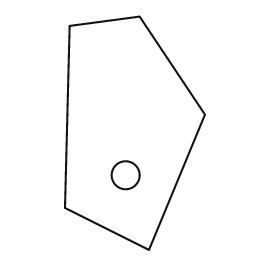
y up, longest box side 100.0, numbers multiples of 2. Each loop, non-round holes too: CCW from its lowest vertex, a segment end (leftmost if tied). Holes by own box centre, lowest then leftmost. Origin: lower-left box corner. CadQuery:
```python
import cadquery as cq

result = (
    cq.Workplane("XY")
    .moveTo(36.0, 0.0)
    .lineTo(60.0, 58.0)
    .lineTo(32.0, 100.0)
    .lineTo(2.0, 96.0)
    .lineTo(0.0, 18.0)
    .close()
    .moveTo(26.0, 32.0)
    .circle(6.0)
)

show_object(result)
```